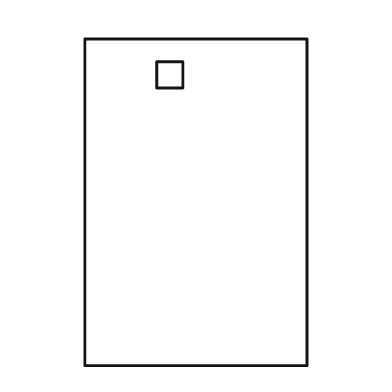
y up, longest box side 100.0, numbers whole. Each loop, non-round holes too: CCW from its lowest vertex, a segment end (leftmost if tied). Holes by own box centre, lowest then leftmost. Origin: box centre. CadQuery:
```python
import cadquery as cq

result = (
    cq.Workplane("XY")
    .moveTo(-34.0, -50.0)
    .lineTo(34.0, -50.0)
    .lineTo(34.0, 50.0)
    .lineTo(-34.0, 50.0)
    .close()
    .moveTo(-12.0, 35.0)
    .lineTo(-4.0, 35.0)
    .lineTo(-4.0, 43.0)
    .lineTo(-12.0, 43.0)
    .close()
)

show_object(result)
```